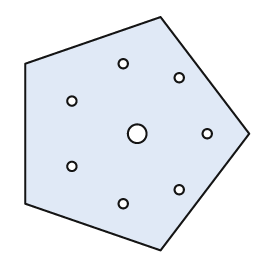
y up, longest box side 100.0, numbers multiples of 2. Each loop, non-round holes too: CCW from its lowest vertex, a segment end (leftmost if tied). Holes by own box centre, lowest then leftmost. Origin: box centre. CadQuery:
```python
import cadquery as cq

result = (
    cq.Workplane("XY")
    .moveTo(10.0, -50.0)
    .lineTo(48.0, 0.0)
    .lineTo(10.0, 50.0)
    .lineTo(-48.0, 30.0)
    .lineTo(-48.0, -30.0)
    .close()
    .moveTo(-6.0, -30.0)
    .circle(2.0)
    .moveTo(18.0, -24.0)
    .circle(2.0)
    .moveTo(-28.0, -14.0)
    .circle(2.0)
    .moveTo(0.0, 0.0)
    .circle(4.0)
    .moveTo(30.0, 0.0)
    .circle(2.0)
    .moveTo(-28.0, 14.0)
    .circle(2.0)
    .moveTo(18.0, 24.0)
    .circle(2.0)
    .moveTo(-6.0, 30.0)
    .circle(2.0)
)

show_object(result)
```